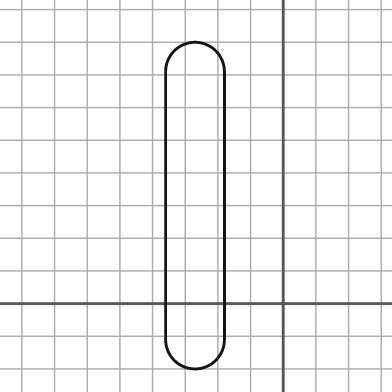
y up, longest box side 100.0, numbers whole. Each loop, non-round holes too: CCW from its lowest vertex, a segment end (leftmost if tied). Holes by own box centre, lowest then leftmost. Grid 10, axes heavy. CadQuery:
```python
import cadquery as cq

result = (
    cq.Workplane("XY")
    .moveTo(-36.0, -11.0)
    .threePointArc((-27.0, -20.0), (-18.0, -11.0))
    .lineTo(-18.0, 71.0)
    .threePointArc((-27.0, 80.0), (-36.0, 71.0))
    .close()
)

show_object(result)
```